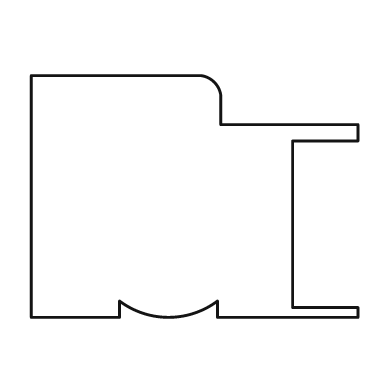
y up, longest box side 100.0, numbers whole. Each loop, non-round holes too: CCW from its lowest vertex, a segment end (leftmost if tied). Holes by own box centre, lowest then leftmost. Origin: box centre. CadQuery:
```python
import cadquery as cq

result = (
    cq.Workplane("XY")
    .moveTo(-50.0, -37.0)
    .lineTo(-23.0, -37.0)
    .lineTo(-23.0, -32.0)
    .threePointArc((-8.0, -37.0), (7.0, -32.0))
    .lineTo(7.0, -37.0)
    .lineTo(50.0, -37.0)
    .lineTo(50.0, -34.0)
    .lineTo(30.0, -34.0)
    .lineTo(30.0, 17.0)
    .lineTo(50.0, 17.0)
    .lineTo(50.0, 22.0)
    .lineTo(8.0, 22.0)
    .lineTo(8.0, 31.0)
    .threePointArc((6.0, 35.0), (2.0, 37.0))
    .lineTo(-50.0, 37.0)
    .close()
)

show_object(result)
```